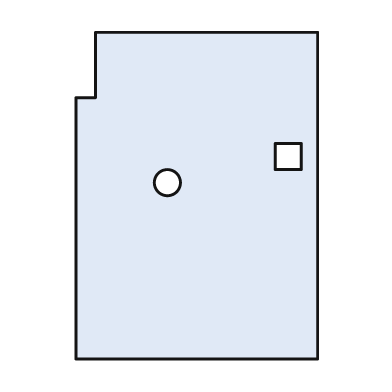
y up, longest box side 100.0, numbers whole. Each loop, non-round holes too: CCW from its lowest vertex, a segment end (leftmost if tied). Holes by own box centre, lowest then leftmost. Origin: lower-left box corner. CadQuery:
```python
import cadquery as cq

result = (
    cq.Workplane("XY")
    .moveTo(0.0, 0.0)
    .lineTo(74.0, 0.0)
    .lineTo(74.0, 100.0)
    .lineTo(6.0, 100.0)
    .lineTo(6.0, 80.0)
    .lineTo(0.0, 80.0)
    .close()
    .moveTo(28.0, 54.0)
    .circle(4.0)
    .moveTo(61.0, 58.0)
    .lineTo(69.0, 58.0)
    .lineTo(69.0, 66.0)
    .lineTo(61.0, 66.0)
    .close()
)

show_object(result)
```